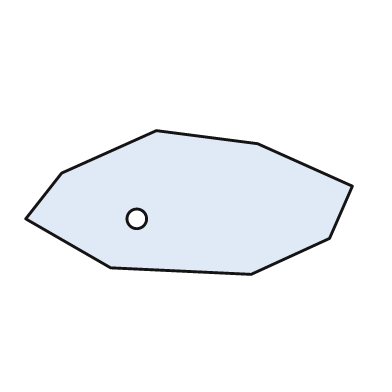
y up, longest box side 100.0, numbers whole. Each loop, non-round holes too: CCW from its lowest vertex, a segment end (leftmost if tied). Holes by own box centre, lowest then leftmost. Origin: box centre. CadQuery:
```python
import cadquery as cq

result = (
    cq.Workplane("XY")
    .moveTo(19.0, -22.0)
    .lineTo(43.0, -11.0)
    .lineTo(50.0, 5.0)
    .lineTo(21.0, 18.0)
    .lineTo(-10.0, 22.0)
    .lineTo(-39.0, 9.0)
    .lineTo(-50.0, -5.0)
    .lineTo(-24.0, -20.0)
    .close()
    .moveTo(-16.0, -5.0)
    .circle(3.0)
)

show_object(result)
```